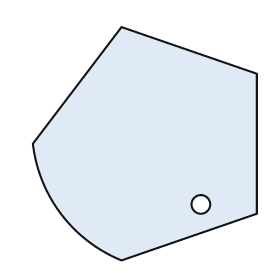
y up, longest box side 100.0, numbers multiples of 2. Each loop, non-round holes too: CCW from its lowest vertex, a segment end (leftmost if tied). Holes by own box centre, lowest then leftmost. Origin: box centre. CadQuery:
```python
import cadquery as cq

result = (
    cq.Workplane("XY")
    .moveTo(-10.0, -50.0)
    .lineTo(48.0, -30.0)
    .lineTo(48.0, 30.0)
    .lineTo(-10.0, 50.0)
    .lineTo(-48.0, 0.0)
    .threePointArc((-36.0, -30.0), (-10.0, -50.0))
    .close()
    .moveTo(24.0, -26.0)
    .circle(4.0)
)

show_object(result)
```